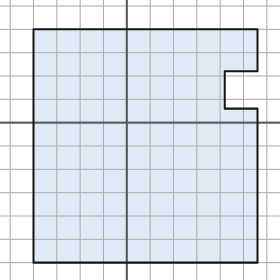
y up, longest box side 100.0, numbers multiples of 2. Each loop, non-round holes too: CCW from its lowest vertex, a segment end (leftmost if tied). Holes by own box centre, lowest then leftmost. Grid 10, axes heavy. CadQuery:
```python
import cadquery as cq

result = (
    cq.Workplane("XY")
    .moveTo(-40.0, -60.0)
    .lineTo(56.0, -60.0)
    .lineTo(56.0, 6.0)
    .lineTo(42.0, 6.0)
    .lineTo(42.0, 22.0)
    .lineTo(56.0, 22.0)
    .lineTo(56.0, 40.0)
    .lineTo(-40.0, 40.0)
    .close()
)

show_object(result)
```